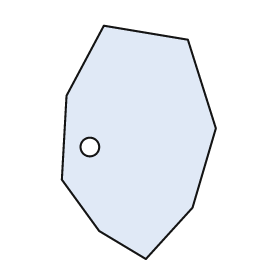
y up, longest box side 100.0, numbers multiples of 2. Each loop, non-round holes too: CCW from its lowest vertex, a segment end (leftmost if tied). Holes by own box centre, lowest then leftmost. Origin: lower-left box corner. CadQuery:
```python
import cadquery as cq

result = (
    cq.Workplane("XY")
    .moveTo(36.0, 0.0)
    .lineTo(56.0, 22.0)
    .lineTo(66.0, 56.0)
    .lineTo(54.0, 94.0)
    .lineTo(18.0, 100.0)
    .lineTo(2.0, 70.0)
    .lineTo(0.0, 34.0)
    .lineTo(16.0, 12.0)
    .close()
    .moveTo(12.0, 48.0)
    .circle(4.0)
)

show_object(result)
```